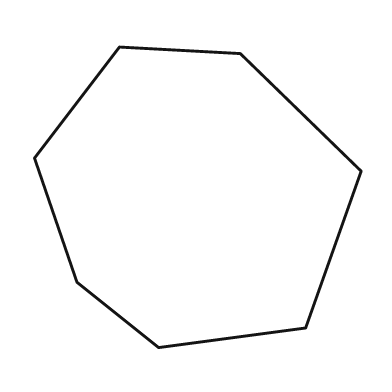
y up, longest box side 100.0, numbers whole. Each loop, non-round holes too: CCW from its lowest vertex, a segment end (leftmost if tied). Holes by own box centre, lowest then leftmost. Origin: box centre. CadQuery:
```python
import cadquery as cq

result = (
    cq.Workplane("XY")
    .moveTo(-12.0, -46.0)
    .lineTo(33.0, -40.0)
    .lineTo(50.0, 8.0)
    .lineTo(13.0, 44.0)
    .lineTo(-24.0, 46.0)
    .lineTo(-50.0, 12.0)
    .lineTo(-37.0, -26.0)
    .close()
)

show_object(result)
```